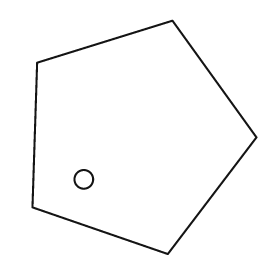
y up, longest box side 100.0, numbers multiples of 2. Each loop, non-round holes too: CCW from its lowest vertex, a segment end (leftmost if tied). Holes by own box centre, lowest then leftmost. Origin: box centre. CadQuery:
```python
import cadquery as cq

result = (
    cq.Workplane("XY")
    .moveTo(10.0, -50.0)
    .lineTo(48.0, 0.0)
    .lineTo(12.0, 50.0)
    .lineTo(-46.0, 32.0)
    .lineTo(-48.0, -30.0)
    .close()
    .moveTo(-26.0, -18.0)
    .circle(4.0)
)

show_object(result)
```